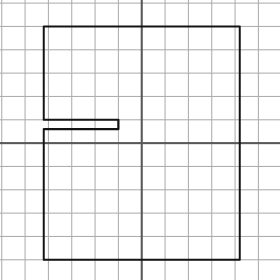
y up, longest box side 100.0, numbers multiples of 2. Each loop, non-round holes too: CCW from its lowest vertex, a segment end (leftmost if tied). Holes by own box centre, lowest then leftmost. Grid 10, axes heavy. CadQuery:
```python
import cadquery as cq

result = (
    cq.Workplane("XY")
    .moveTo(-42.0, -50.0)
    .lineTo(42.0, -50.0)
    .lineTo(42.0, 50.0)
    .lineTo(-42.0, 50.0)
    .lineTo(-42.0, 10.0)
    .lineTo(-10.0, 10.0)
    .lineTo(-10.0, 6.0)
    .lineTo(-42.0, 6.0)
    .close()
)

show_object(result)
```